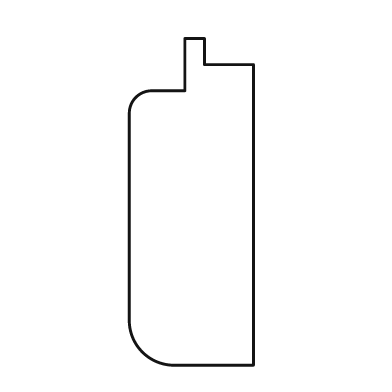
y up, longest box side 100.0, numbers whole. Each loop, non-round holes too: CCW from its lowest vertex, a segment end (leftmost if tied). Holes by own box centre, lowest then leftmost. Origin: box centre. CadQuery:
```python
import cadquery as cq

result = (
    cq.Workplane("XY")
    .moveTo(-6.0, -50.0)
    .lineTo(19.0, -50.0)
    .lineTo(19.0, 42.0)
    .lineTo(4.0, 42.0)
    .lineTo(4.0, 50.0)
    .lineTo(-2.0, 50.0)
    .lineTo(-2.0, 34.0)
    .lineTo(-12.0, 34.0)
    .threePointArc((-17.0, 32.0), (-19.0, 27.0))
    .lineTo(-19.0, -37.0)
    .threePointArc((-15.0, -46.0), (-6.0, -50.0))
    .close()
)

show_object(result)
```